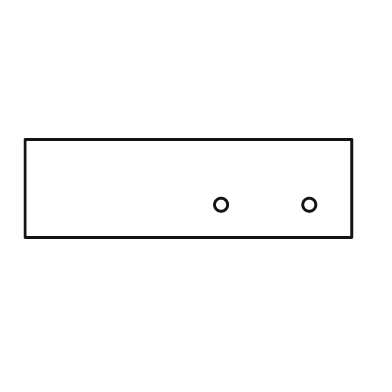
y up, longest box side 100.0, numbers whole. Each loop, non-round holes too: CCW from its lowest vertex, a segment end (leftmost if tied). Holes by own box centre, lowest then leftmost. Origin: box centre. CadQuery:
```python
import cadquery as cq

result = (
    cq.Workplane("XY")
    .moveTo(-50.0, -15.0)
    .lineTo(50.0, -15.0)
    .lineTo(50.0, 15.0)
    .lineTo(-50.0, 15.0)
    .close()
    .moveTo(10.0, -5.0)
    .circle(2.0)
    .moveTo(37.0, -5.0)
    .circle(2.0)
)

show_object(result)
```